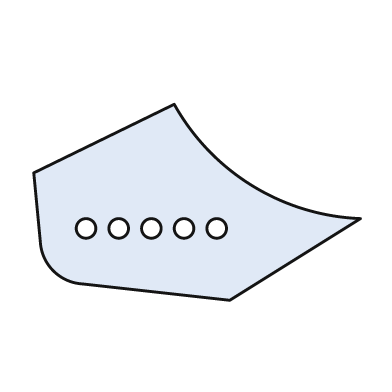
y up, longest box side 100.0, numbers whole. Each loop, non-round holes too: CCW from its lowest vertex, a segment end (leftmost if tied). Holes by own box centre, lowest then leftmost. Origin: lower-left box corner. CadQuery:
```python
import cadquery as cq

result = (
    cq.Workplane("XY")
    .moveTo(60.0, 0.0)
    .lineTo(100.0, 25.0)
    .threePointArc((67.0, 35.0), (43.0, 60.0))
    .lineTo(0.0, 39.0)
    .lineTo(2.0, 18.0)
    .threePointArc((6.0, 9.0), (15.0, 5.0))
    .close()
    .moveTo(16.0, 22.0)
    .circle(3.0)
    .moveTo(26.0, 22.0)
    .circle(3.0)
    .moveTo(36.0, 22.0)
    .circle(3.0)
    .moveTo(46.0, 22.0)
    .circle(3.0)
    .moveTo(56.0, 22.0)
    .circle(3.0)
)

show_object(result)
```